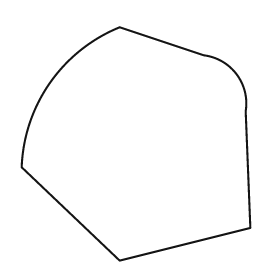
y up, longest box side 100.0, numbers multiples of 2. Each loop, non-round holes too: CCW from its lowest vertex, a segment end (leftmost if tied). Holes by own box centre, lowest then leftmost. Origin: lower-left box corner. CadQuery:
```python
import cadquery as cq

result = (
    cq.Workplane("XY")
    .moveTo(42.0, 0.0)
    .lineTo(98.0, 14.0)
    .lineTo(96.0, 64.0)
    .threePointArc((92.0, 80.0), (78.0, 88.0))
    .lineTo(42.0, 100.0)
    .threePointArc((12.0, 76.0), (0.0, 40.0))
    .close()
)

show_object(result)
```